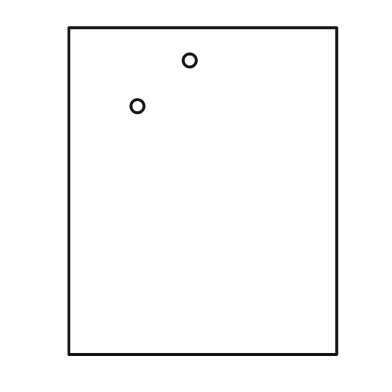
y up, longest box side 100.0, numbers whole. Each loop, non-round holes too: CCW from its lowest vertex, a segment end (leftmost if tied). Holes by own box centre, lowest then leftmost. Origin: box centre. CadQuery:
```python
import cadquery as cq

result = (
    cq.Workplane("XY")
    .moveTo(-41.0, -50.0)
    .lineTo(41.0, -50.0)
    .lineTo(41.0, 50.0)
    .lineTo(-41.0, 50.0)
    .close()
    .moveTo(-20.0, 26.0)
    .circle(2.0)
    .moveTo(-4.0, 40.0)
    .circle(2.0)
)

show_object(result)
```